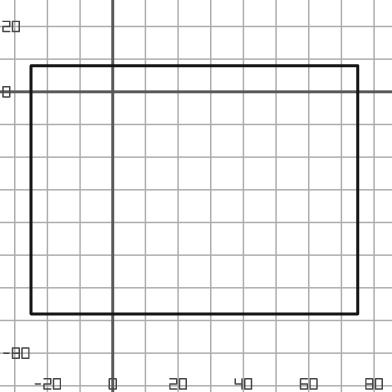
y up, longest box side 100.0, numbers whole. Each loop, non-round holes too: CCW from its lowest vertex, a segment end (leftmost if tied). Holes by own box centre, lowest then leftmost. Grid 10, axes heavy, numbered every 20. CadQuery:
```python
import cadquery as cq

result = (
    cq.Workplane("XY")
    .moveTo(-25.0, -68.0)
    .lineTo(75.0, -68.0)
    .lineTo(75.0, 8.0)
    .lineTo(-25.0, 8.0)
    .close()
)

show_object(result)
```